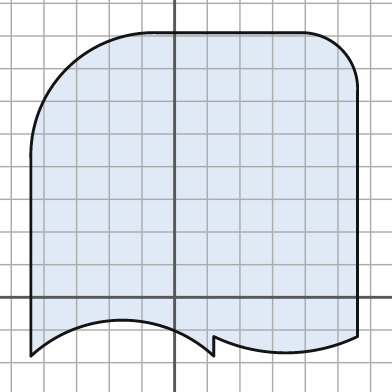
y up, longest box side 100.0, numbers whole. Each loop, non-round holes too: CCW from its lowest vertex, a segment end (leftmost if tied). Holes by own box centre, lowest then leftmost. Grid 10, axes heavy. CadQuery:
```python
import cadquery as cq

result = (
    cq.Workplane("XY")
    .moveTo(-44.0, -18.0)
    .threePointArc((-16.0, -7.0), (12.0, -18.0))
    .lineTo(12.0, -12.0)
    .threePointArc((34.0, -17.0), (56.0, -12.0))
    .lineTo(56.0, 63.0)
    .threePointArc((51.0, 76.0), (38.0, 81.0))
    .lineTo(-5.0, 81.0)
    .threePointArc((-33.0, 70.0), (-44.0, 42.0))
    .close()
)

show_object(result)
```